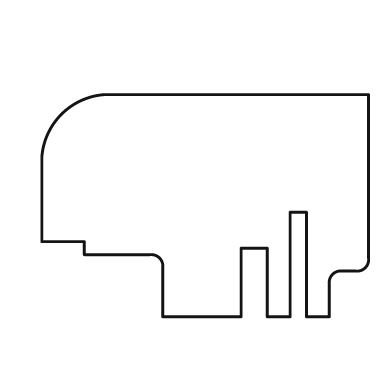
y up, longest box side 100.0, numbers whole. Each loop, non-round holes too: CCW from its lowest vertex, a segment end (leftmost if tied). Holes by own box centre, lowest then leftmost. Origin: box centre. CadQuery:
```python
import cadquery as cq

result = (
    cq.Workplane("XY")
    .moveTo(-13.0, -34.0)
    .lineTo(11.0, -34.0)
    .lineTo(11.0, -13.0)
    .lineTo(19.0, -13.0)
    .lineTo(19.0, -34.0)
    .lineTo(26.0, -34.0)
    .lineTo(26.0, -2.0)
    .lineTo(31.0, -2.0)
    .lineTo(31.0, -34.0)
    .lineTo(38.0, -34.0)
    .lineTo(38.0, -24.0)
    .threePointArc((39.0, -21.0), (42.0, -20.0))
    .lineTo(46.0, -20.0)
    .threePointArc((49.0, -19.0), (50.0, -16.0))
    .lineTo(50.0, 34.0)
    .lineTo(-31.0, 34.0)
    .threePointArc((-44.0, 28.0), (-50.0, 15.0))
    .lineTo(-50.0, -11.0)
    .lineTo(-37.0, -11.0)
    .lineTo(-37.0, -15.0)
    .lineTo(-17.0, -15.0)
    .threePointArc((-14.0, -16.0), (-13.0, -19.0))
    .close()
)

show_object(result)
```